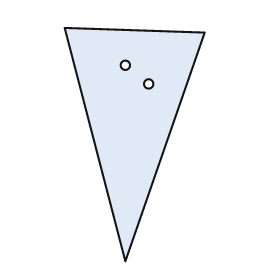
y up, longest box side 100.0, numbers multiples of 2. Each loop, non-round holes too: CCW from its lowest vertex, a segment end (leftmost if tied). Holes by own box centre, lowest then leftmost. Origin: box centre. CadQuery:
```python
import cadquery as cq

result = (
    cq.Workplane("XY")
    .moveTo(-4.0, -50.0)
    .lineTo(30.0, 48.0)
    .lineTo(-30.0, 50.0)
    .close()
    .moveTo(6.0, 26.0)
    .circle(2.0)
    .moveTo(-4.0, 34.0)
    .circle(2.0)
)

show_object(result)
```